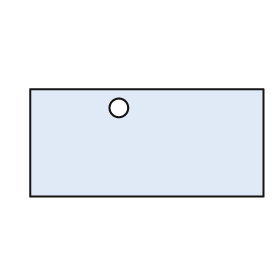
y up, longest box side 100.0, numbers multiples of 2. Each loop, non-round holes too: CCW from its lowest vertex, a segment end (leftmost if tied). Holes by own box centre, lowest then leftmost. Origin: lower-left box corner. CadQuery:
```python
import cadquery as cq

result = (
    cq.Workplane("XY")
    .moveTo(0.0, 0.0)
    .lineTo(100.0, 0.0)
    .lineTo(100.0, 46.0)
    .lineTo(0.0, 46.0)
    .close()
    .moveTo(38.0, 38.0)
    .circle(4.0)
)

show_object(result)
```